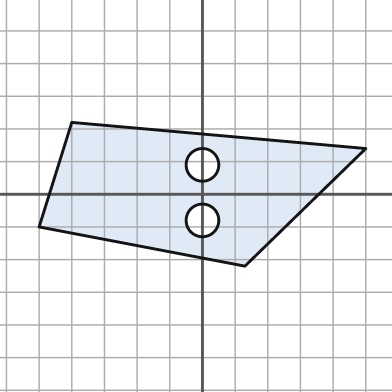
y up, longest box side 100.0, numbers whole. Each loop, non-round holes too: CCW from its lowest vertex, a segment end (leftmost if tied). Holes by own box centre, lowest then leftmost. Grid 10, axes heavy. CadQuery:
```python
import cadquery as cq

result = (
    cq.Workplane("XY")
    .moveTo(13.0, -22.0)
    .lineTo(50.0, 14.0)
    .lineTo(-40.0, 22.0)
    .lineTo(-50.0, -10.0)
    .close()
    .moveTo(0.0, -8.0)
    .circle(5.0)
    .moveTo(0.0, 9.0)
    .circle(5.0)
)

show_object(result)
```